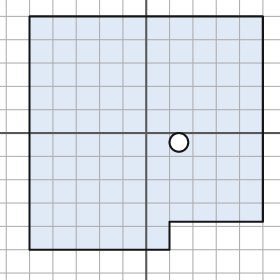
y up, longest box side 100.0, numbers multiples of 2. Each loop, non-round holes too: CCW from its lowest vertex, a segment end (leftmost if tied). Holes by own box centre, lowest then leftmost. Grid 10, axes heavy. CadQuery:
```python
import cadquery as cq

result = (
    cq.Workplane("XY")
    .moveTo(-50.0, -50.0)
    .lineTo(10.0, -50.0)
    .lineTo(10.0, -38.0)
    .lineTo(50.0, -38.0)
    .lineTo(50.0, 50.0)
    .lineTo(-50.0, 50.0)
    .close()
    .moveTo(14.0, -4.0)
    .circle(4.0)
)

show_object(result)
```